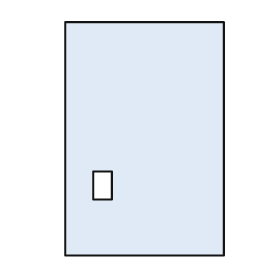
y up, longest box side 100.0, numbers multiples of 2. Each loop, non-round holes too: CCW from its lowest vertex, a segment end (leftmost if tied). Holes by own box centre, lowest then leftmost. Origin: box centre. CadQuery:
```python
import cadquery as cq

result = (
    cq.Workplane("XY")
    .moveTo(-34.0, -50.0)
    .lineTo(34.0, -50.0)
    .lineTo(34.0, 50.0)
    .lineTo(-34.0, 50.0)
    .close()
    .moveTo(-22.0, -26.0)
    .lineTo(-14.0, -26.0)
    .lineTo(-14.0, -14.0)
    .lineTo(-22.0, -14.0)
    .close()
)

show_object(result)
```